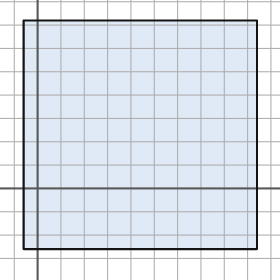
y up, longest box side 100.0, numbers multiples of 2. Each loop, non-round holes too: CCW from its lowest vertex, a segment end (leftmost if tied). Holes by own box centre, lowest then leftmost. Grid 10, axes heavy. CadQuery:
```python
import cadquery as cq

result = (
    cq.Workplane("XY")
    .moveTo(-6.0, -26.0)
    .lineTo(94.0, -26.0)
    .lineTo(94.0, 72.0)
    .lineTo(-6.0, 72.0)
    .close()
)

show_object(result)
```